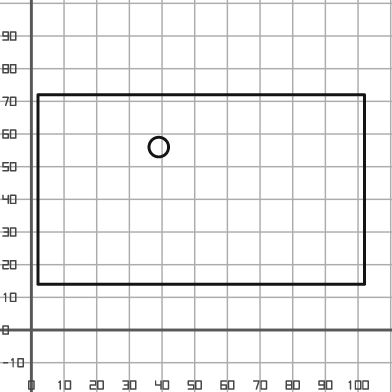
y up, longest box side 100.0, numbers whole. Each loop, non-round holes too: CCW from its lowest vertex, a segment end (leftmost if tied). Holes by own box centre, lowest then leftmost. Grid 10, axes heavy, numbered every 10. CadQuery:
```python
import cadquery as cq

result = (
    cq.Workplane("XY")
    .moveTo(2.0, 14.0)
    .lineTo(102.0, 14.0)
    .lineTo(102.0, 72.0)
    .lineTo(2.0, 72.0)
    .close()
    .moveTo(39.0, 56.0)
    .circle(3.0)
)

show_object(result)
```